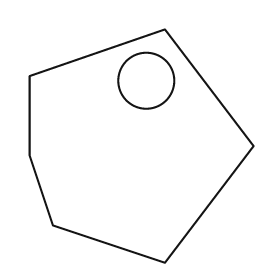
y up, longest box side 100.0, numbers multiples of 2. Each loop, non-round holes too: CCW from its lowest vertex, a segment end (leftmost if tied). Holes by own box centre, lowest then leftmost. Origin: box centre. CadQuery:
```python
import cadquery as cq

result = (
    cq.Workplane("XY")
    .moveTo(10.0, -50.0)
    .lineTo(48.0, 0.0)
    .lineTo(10.0, 50.0)
    .lineTo(-48.0, 30.0)
    .lineTo(-48.0, -4.0)
    .lineTo(-38.0, -34.0)
    .close()
    .moveTo(2.0, 28.0)
    .circle(12.0)
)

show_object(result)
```